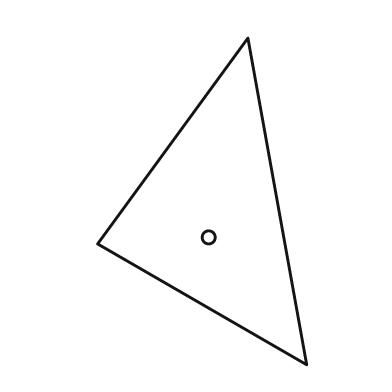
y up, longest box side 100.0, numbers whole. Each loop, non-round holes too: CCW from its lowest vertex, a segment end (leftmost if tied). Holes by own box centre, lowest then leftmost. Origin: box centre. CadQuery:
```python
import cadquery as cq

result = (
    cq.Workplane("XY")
    .moveTo(32.0, -50.0)
    .lineTo(14.0, 50.0)
    .lineTo(-32.0, -13.0)
    .close()
    .moveTo(2.0, -11.0)
    .circle(2.0)
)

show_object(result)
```